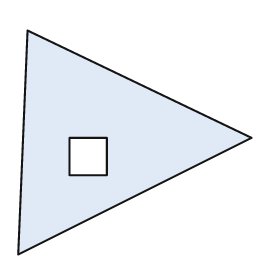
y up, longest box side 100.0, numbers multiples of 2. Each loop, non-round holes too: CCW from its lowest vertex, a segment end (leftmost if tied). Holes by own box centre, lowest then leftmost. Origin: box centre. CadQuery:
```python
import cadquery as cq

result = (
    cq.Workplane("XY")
    .moveTo(-50.0, -48.0)
    .lineTo(50.0, 2.0)
    .lineTo(-46.0, 48.0)
    .close()
    .moveTo(-28.0, -14.0)
    .lineTo(-12.0, -14.0)
    .lineTo(-12.0, 2.0)
    .lineTo(-28.0, 2.0)
    .close()
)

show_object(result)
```